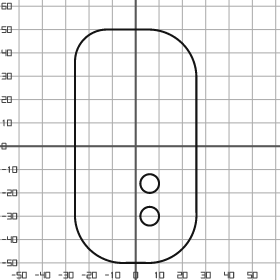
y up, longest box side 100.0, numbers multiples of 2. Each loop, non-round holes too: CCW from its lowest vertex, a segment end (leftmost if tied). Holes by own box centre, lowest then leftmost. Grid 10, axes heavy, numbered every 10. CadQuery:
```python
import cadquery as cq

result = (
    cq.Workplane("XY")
    .moveTo(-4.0, -50.0)
    .lineTo(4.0, -50.0)
    .threePointArc((20.0, -44.0), (26.0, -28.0))
    .lineTo(26.0, 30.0)
    .threePointArc((20.0, 44.0), (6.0, 50.0))
    .lineTo(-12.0, 50.0)
    .threePointArc((-22.0, 46.0), (-26.0, 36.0))
    .lineTo(-26.0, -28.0)
    .threePointArc((-20.0, -44.0), (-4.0, -50.0))
    .close()
    .moveTo(6.0, -30.0)
    .circle(4.0)
    .moveTo(6.0, -16.0)
    .circle(4.0)
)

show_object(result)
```